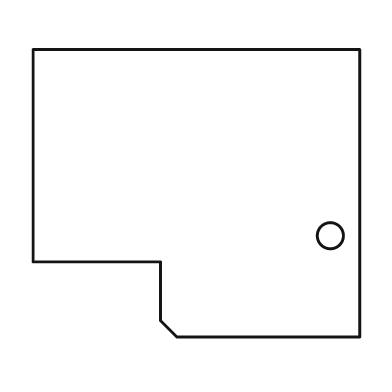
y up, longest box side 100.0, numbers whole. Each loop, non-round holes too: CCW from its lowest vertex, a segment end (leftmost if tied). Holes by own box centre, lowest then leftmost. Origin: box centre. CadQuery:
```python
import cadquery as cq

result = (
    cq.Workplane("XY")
    .moveTo(-6.0, -44.0)
    .lineTo(50.0, -44.0)
    .lineTo(50.0, 44.0)
    .lineTo(-50.0, 44.0)
    .lineTo(-50.0, -21.0)
    .lineTo(-11.0, -21.0)
    .lineTo(-11.0, -39.0)
    .close()
    .moveTo(41.0, -13.0)
    .circle(4.0)
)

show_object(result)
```